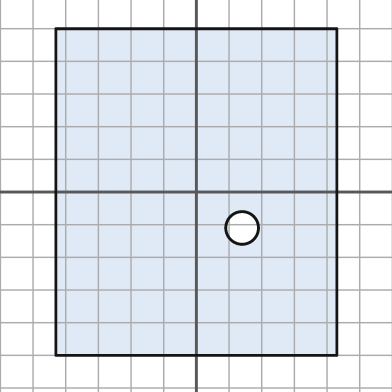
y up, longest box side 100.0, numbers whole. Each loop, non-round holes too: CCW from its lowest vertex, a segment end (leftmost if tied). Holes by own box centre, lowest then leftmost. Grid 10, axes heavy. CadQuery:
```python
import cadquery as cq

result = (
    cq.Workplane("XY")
    .moveTo(-43.0, -50.0)
    .lineTo(43.0, -50.0)
    .lineTo(43.0, 50.0)
    .lineTo(-43.0, 50.0)
    .close()
    .moveTo(14.0, -11.0)
    .circle(5.0)
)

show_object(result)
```